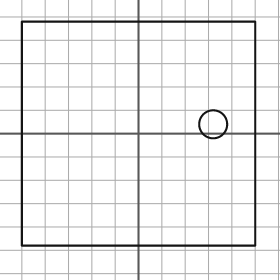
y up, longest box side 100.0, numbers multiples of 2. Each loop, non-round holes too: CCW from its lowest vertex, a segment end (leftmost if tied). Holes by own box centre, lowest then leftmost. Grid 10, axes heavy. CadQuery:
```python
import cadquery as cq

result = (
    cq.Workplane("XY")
    .moveTo(-50.0, -48.0)
    .lineTo(50.0, -48.0)
    .lineTo(50.0, 48.0)
    .lineTo(-50.0, 48.0)
    .close()
    .moveTo(32.0, 4.0)
    .circle(6.0)
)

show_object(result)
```